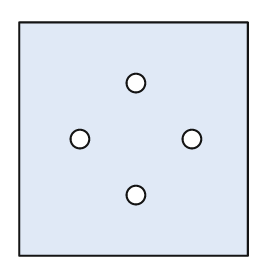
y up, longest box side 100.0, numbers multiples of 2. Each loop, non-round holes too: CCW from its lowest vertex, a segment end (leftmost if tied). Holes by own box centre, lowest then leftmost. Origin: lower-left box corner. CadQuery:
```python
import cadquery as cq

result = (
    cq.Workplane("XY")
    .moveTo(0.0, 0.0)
    .lineTo(98.0, 0.0)
    .lineTo(98.0, 100.0)
    .lineTo(0.0, 100.0)
    .close()
    .moveTo(50.0, 26.0)
    .circle(4.0)
    .moveTo(26.0, 50.0)
    .circle(4.0)
    .moveTo(74.0, 50.0)
    .circle(4.0)
    .moveTo(50.0, 74.0)
    .circle(4.0)
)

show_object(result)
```